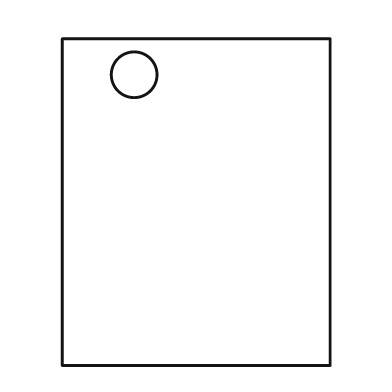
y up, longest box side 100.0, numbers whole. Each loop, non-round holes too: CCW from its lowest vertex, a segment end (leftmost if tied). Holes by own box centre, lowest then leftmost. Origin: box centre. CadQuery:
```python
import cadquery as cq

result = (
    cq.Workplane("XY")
    .moveTo(-41.0, -50.0)
    .lineTo(41.0, -50.0)
    .lineTo(41.0, 50.0)
    .lineTo(-41.0, 50.0)
    .close()
    .moveTo(-19.0, 39.0)
    .circle(7.0)
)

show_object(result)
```